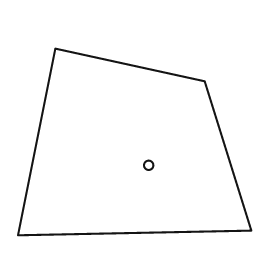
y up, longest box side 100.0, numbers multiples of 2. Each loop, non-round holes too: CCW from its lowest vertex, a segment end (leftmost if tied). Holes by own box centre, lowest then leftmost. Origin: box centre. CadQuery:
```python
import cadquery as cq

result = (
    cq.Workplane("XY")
    .moveTo(-50.0, -40.0)
    .lineTo(50.0, -38.0)
    .lineTo(30.0, 26.0)
    .lineTo(-34.0, 40.0)
    .close()
    .moveTo(6.0, -10.0)
    .circle(2.0)
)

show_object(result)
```